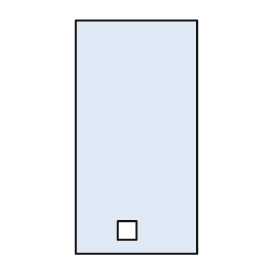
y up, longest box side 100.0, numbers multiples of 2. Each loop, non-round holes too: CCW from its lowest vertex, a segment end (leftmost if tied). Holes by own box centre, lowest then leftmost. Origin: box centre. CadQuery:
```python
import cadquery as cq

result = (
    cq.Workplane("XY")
    .moveTo(-26.0, -50.0)
    .lineTo(26.0, -50.0)
    .lineTo(26.0, 50.0)
    .lineTo(-26.0, 50.0)
    .close()
    .moveTo(-8.0, -44.0)
    .lineTo(0.0, -44.0)
    .lineTo(0.0, -36.0)
    .lineTo(-8.0, -36.0)
    .close()
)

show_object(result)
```